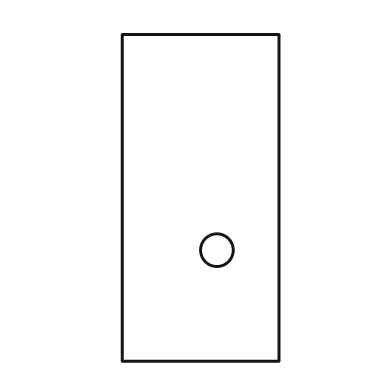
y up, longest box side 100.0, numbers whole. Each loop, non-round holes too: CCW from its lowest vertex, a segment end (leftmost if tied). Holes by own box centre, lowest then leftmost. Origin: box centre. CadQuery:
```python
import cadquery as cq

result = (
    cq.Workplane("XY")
    .moveTo(-24.0, -50.0)
    .lineTo(24.0, -50.0)
    .lineTo(24.0, 50.0)
    .lineTo(-24.0, 50.0)
    .close()
    .moveTo(5.0, -16.0)
    .circle(5.0)
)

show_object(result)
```